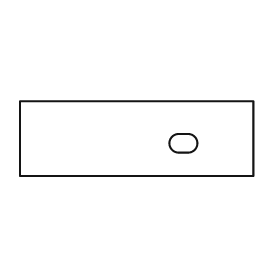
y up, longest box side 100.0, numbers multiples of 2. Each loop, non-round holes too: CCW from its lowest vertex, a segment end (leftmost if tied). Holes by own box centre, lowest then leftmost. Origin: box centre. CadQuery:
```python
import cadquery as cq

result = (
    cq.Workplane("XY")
    .moveTo(-50.0, -16.0)
    .lineTo(50.0, -16.0)
    .lineTo(50.0, 16.0)
    .lineTo(-50.0, 16.0)
    .close()
    .moveTo(18.0, -6.0)
    .lineTo(22.0, -6.0)
    .threePointArc((26.0, -2.0), (22.0, 2.0))
    .lineTo(18.0, 2.0)
    .threePointArc((14.0, -2.0), (18.0, -6.0))
    .close()
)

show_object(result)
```